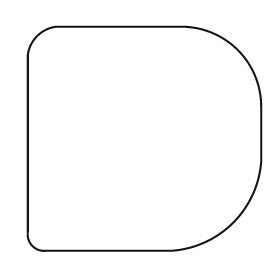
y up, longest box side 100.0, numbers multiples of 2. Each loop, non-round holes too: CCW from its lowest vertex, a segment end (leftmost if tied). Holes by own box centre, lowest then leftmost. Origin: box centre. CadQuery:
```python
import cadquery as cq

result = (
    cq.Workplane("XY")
    .moveTo(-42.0, -48.0)
    .lineTo(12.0, -48.0)
    .threePointArc((38.0, -36.0), (50.0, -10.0))
    .lineTo(50.0, 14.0)
    .threePointArc((40.0, 38.0), (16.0, 48.0))
    .lineTo(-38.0, 48.0)
    .threePointArc((-46.0, 44.0), (-50.0, 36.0))
    .lineTo(-50.0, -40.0)
    .threePointArc((-48.0, -46.0), (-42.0, -48.0))
    .close()
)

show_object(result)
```